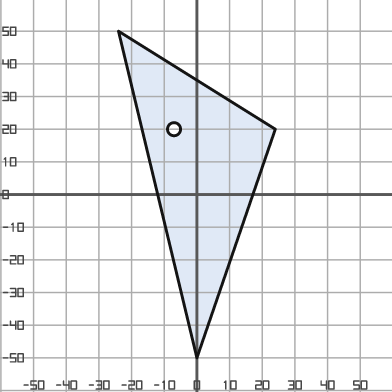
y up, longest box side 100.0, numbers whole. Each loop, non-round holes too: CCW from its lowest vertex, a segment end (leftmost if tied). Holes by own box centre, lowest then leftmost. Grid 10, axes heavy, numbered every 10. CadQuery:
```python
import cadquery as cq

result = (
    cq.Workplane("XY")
    .moveTo(0.0, -50.0)
    .lineTo(24.0, 20.0)
    .lineTo(-24.0, 50.0)
    .close()
    .moveTo(-7.0, 20.0)
    .circle(2.0)
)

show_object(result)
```